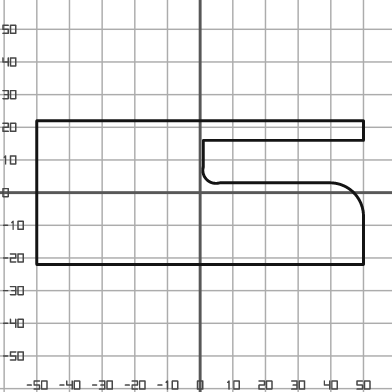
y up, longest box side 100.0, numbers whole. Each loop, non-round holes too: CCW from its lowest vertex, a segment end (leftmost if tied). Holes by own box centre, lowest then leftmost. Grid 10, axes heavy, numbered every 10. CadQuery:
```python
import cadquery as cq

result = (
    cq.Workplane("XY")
    .moveTo(-50.0, -22.0)
    .lineTo(50.0, -22.0)
    .lineTo(50.0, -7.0)
    .threePointArc((47.0, 0.0), (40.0, 3.0))
    .lineTo(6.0, 3.0)
    .threePointArc((2.0, 4.0), (1.0, 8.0))
    .lineTo(1.0, 16.0)
    .lineTo(50.0, 16.0)
    .lineTo(50.0, 22.0)
    .lineTo(-50.0, 22.0)
    .close()
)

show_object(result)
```